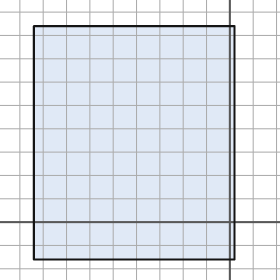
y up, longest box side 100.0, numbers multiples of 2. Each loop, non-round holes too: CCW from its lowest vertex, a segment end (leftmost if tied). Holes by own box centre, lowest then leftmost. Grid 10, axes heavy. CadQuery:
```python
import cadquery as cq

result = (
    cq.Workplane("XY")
    .moveTo(-84.0, -16.0)
    .lineTo(2.0, -16.0)
    .lineTo(2.0, 84.0)
    .lineTo(-84.0, 84.0)
    .close()
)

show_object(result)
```